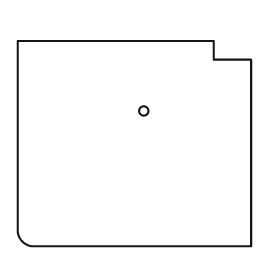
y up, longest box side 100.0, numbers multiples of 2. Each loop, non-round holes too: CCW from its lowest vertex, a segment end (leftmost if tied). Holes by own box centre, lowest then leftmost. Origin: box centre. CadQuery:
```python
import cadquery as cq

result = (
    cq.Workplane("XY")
    .moveTo(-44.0, -44.0)
    .lineTo(50.0, -44.0)
    .lineTo(50.0, 36.0)
    .lineTo(34.0, 36.0)
    .lineTo(34.0, 44.0)
    .lineTo(-50.0, 44.0)
    .lineTo(-50.0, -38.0)
    .threePointArc((-48.0, -42.0), (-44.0, -44.0))
    .close()
    .moveTo(4.0, 14.0)
    .circle(2.0)
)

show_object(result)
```